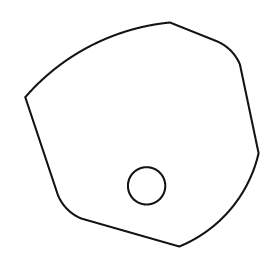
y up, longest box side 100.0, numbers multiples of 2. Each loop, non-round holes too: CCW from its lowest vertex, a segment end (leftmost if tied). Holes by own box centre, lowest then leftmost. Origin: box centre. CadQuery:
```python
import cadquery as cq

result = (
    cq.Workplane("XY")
    .moveTo(16.0, -48.0)
    .threePointArc((38.0, -32.0), (50.0, -8.0))
    .lineTo(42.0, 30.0)
    .threePointArc((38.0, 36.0), (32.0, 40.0))
    .lineTo(12.0, 48.0)
    .threePointArc((-22.0, 38.0), (-50.0, 16.0))
    .lineTo(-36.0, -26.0)
    .threePointArc((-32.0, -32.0), (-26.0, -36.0))
    .close()
    .moveTo(2.0, -22.0)
    .circle(8.0)
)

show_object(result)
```